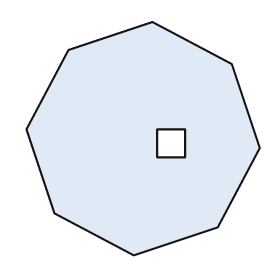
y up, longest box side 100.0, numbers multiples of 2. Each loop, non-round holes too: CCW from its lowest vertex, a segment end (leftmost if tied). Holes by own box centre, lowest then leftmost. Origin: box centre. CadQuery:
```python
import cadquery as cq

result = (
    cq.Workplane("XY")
    .moveTo(-4.0, -50.0)
    .lineTo(32.0, -38.0)
    .lineTo(50.0, -4.0)
    .lineTo(38.0, 32.0)
    .lineTo(4.0, 50.0)
    .lineTo(-32.0, 38.0)
    .lineTo(-50.0, 4.0)
    .lineTo(-38.0, -32.0)
    .close()
    .moveTo(6.0, -8.0)
    .lineTo(18.0, -8.0)
    .lineTo(18.0, 4.0)
    .lineTo(6.0, 4.0)
    .close()
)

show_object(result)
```